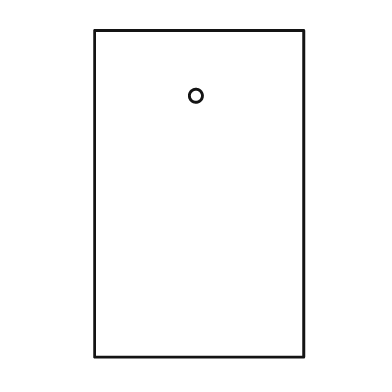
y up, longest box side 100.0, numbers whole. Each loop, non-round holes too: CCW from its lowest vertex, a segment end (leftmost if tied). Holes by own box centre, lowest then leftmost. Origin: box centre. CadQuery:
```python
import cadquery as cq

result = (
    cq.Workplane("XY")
    .moveTo(-32.0, -50.0)
    .lineTo(32.0, -50.0)
    .lineTo(32.0, 50.0)
    .lineTo(-32.0, 50.0)
    .close()
    .moveTo(-1.0, 30.0)
    .circle(2.0)
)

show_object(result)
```